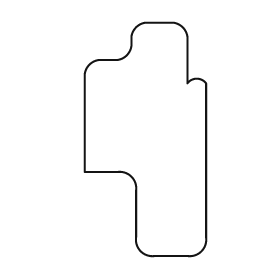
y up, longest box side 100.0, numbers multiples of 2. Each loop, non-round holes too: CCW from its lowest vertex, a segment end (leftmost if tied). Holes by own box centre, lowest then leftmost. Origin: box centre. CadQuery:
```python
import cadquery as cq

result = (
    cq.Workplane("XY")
    .moveTo(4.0, -50.0)
    .lineTo(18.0, -50.0)
    .threePointArc((24.0, -48.0), (26.0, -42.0))
    .lineTo(26.0, 24.0)
    .threePointArc((22.0, 26.0), (18.0, 24.0))
    .lineTo(18.0, 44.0)
    .threePointArc((16.0, 48.0), (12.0, 50.0))
    .lineTo(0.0, 50.0)
    .threePointArc((-4.0, 48.0), (-6.0, 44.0))
    .lineTo(-6.0, 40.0)
    .threePointArc((-8.0, 36.0), (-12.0, 34.0))
    .lineTo(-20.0, 34.0)
    .threePointArc((-24.0, 32.0), (-26.0, 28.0))
    .lineTo(-26.0, -14.0)
    .lineTo(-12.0, -14.0)
    .threePointArc((-6.0, -16.0), (-4.0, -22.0))
    .lineTo(-4.0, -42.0)
    .threePointArc((-2.0, -48.0), (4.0, -50.0))
    .close()
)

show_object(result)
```